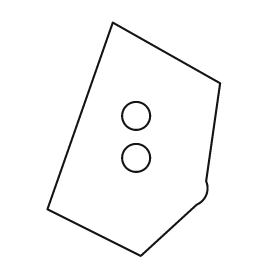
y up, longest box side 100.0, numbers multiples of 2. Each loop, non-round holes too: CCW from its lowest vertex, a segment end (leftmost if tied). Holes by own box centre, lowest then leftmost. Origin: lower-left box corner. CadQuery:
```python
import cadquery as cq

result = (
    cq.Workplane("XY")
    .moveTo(40.0, 0.0)
    .lineTo(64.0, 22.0)
    .threePointArc((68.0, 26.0), (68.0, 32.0))
    .lineTo(74.0, 74.0)
    .lineTo(28.0, 100.0)
    .lineTo(0.0, 20.0)
    .close()
    .moveTo(38.0, 42.0)
    .circle(6.0)
    .moveTo(38.0, 60.0)
    .circle(6.0)
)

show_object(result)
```